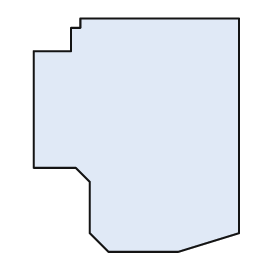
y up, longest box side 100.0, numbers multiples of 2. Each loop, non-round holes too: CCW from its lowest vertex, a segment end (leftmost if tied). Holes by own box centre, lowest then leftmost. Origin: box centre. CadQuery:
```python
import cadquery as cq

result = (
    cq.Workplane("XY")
    .moveTo(-12.0, -50.0)
    .lineTo(18.0, -50.0)
    .lineTo(44.0, -42.0)
    .lineTo(44.0, 50.0)
    .lineTo(-24.0, 50.0)
    .lineTo(-24.0, 46.0)
    .lineTo(-28.0, 46.0)
    .lineTo(-28.0, 36.0)
    .lineTo(-44.0, 36.0)
    .lineTo(-44.0, -14.0)
    .lineTo(-26.0, -14.0)
    .lineTo(-20.0, -20.0)
    .lineTo(-20.0, -42.0)
    .close()
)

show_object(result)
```